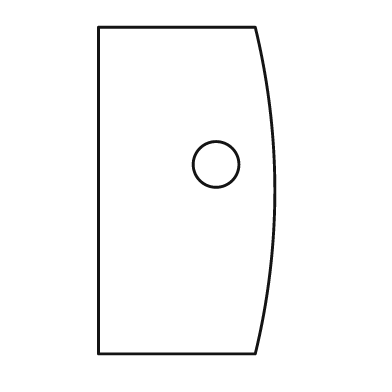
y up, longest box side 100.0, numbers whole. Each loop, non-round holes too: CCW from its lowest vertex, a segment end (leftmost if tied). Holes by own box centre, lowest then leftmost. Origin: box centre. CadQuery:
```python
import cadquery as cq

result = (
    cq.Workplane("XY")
    .moveTo(-27.0, -50.0)
    .lineTo(21.0, -50.0)
    .threePointArc((27.0, 0.0), (21.0, 50.0))
    .lineTo(-27.0, 50.0)
    .close()
    .moveTo(9.0, 8.0)
    .circle(7.0)
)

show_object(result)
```